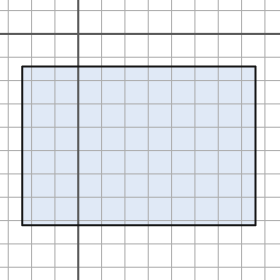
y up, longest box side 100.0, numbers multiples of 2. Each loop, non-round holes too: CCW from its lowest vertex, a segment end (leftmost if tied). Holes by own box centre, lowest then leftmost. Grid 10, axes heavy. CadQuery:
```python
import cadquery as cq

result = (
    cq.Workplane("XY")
    .moveTo(-24.0, -82.0)
    .lineTo(76.0, -82.0)
    .lineTo(76.0, -14.0)
    .lineTo(-24.0, -14.0)
    .close()
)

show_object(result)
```